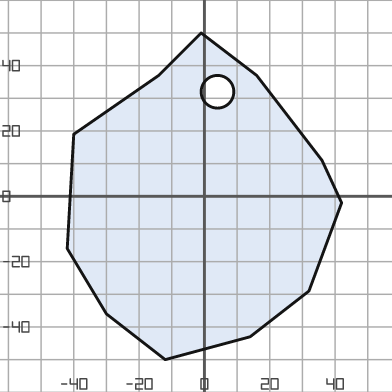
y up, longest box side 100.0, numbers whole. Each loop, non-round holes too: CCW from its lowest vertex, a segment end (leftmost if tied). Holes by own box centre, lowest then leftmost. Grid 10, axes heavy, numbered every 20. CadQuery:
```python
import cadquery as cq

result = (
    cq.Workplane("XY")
    .moveTo(-12.0, -50.0)
    .lineTo(14.0, -43.0)
    .lineTo(32.0, -29.0)
    .lineTo(42.0, -2.0)
    .lineTo(36.0, 11.0)
    .lineTo(16.0, 37.0)
    .lineTo(-1.0, 50.0)
    .lineTo(-14.0, 37.0)
    .lineTo(-40.0, 19.0)
    .lineTo(-42.0, -16.0)
    .lineTo(-30.0, -36.0)
    .close()
    .moveTo(4.0, 32.0)
    .circle(5.0)
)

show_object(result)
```